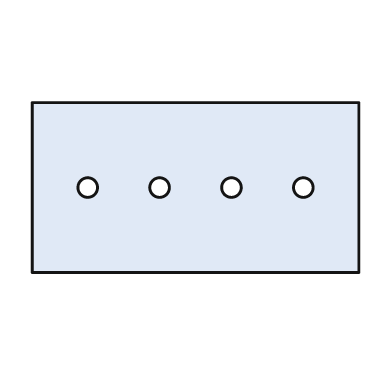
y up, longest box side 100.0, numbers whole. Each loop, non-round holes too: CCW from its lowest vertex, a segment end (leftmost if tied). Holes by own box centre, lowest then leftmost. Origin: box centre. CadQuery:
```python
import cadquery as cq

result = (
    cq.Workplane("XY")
    .moveTo(-50.0, -26.0)
    .lineTo(50.0, -26.0)
    .lineTo(50.0, 26.0)
    .lineTo(-50.0, 26.0)
    .close()
    .moveTo(-33.0, 0.0)
    .circle(3.0)
    .moveTo(-11.0, 0.0)
    .circle(3.0)
    .moveTo(11.0, 0.0)
    .circle(3.0)
    .moveTo(33.0, 0.0)
    .circle(3.0)
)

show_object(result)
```